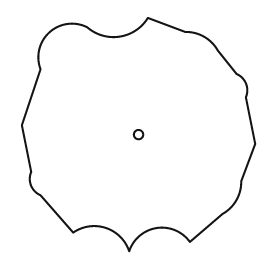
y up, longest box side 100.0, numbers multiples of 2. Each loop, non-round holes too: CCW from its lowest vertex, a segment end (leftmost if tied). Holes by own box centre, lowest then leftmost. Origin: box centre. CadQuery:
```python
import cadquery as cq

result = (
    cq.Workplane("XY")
    .moveTo(-4.0, -50.0)
    .threePointArc((8.0, -40.0), (22.0, -46.0))
    .lineTo(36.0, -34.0)
    .threePointArc((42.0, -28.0), (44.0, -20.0))
    .lineTo(50.0, -4.0)
    .lineTo(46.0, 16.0)
    .threePointArc((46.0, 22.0), (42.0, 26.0))
    .lineTo(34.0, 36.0)
    .threePointArc((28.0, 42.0), (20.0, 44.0))
    .lineTo(4.0, 50.0)
    .threePointArc((-8.0, 42.0), (-22.0, 46.0))
    .threePointArc((-38.0, 44.0), (-42.0, 28.0))
    .lineTo(-50.0, 4.0)
    .lineTo(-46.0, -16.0)
    .threePointArc((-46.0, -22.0), (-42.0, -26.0))
    .lineTo(-28.0, -42.0)
    .threePointArc((-14.0, -40.0), (-4.0, -50.0))
    .close()
    .moveTo(0.0, 0.0)
    .circle(2.0)
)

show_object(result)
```